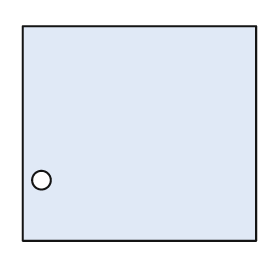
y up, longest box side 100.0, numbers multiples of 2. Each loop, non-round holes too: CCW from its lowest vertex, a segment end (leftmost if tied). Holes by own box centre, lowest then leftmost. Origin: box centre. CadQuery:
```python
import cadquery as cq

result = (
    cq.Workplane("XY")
    .moveTo(-50.0, -46.0)
    .lineTo(50.0, -46.0)
    .lineTo(50.0, 46.0)
    .lineTo(-50.0, 46.0)
    .close()
    .moveTo(-42.0, -20.0)
    .circle(4.0)
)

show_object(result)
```